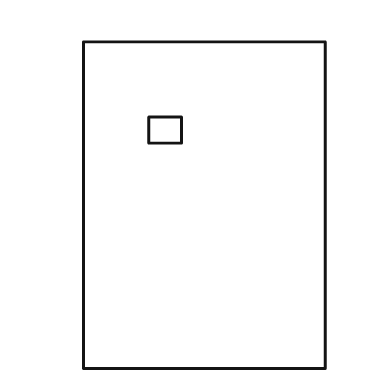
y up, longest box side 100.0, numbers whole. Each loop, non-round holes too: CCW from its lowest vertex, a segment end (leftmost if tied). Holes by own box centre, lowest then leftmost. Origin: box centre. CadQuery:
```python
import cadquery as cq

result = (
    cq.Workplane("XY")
    .moveTo(-37.0, -50.0)
    .lineTo(37.0, -50.0)
    .lineTo(37.0, 50.0)
    .lineTo(-37.0, 50.0)
    .close()
    .moveTo(-17.0, 19.0)
    .lineTo(-7.0, 19.0)
    .lineTo(-7.0, 27.0)
    .lineTo(-17.0, 27.0)
    .close()
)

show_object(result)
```